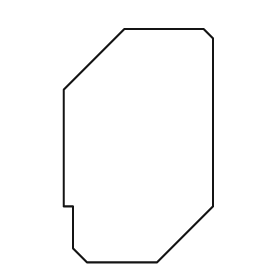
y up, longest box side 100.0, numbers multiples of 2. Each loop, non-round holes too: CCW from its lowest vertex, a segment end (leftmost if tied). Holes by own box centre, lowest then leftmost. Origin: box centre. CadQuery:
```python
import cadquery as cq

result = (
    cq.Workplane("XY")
    .moveTo(-22.0, -50.0)
    .lineTo(8.0, -50.0)
    .lineTo(32.0, -26.0)
    .lineTo(32.0, 46.0)
    .lineTo(28.0, 50.0)
    .lineTo(-6.0, 50.0)
    .lineTo(-32.0, 24.0)
    .lineTo(-32.0, -26.0)
    .lineTo(-28.0, -26.0)
    .lineTo(-28.0, -44.0)
    .close()
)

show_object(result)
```